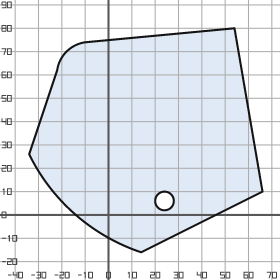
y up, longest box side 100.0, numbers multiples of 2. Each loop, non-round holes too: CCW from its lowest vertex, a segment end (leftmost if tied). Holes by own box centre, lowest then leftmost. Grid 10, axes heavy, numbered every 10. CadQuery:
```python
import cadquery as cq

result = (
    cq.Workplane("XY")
    .moveTo(14.0, -16.0)
    .lineTo(66.0, 10.0)
    .lineTo(54.0, 80.0)
    .lineTo(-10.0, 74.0)
    .threePointArc((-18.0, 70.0), (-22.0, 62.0))
    .lineTo(-34.0, 26.0)
    .threePointArc((-14.0, 0.0), (14.0, -16.0))
    .close()
    .moveTo(24.0, 6.0)
    .circle(4.0)
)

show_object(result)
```